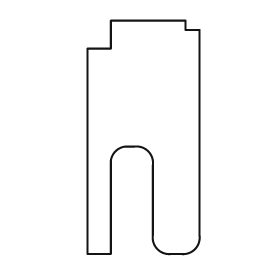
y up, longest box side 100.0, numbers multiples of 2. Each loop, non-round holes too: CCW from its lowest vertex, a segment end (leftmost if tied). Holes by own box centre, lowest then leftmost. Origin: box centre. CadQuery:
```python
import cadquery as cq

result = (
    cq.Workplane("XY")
    .moveTo(-24.0, -50.0)
    .lineTo(-14.0, -50.0)
    .lineTo(-14.0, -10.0)
    .threePointArc((-12.0, -6.0), (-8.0, -4.0))
    .lineTo(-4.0, -4.0)
    .threePointArc((2.0, -6.0), (4.0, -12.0))
    .lineTo(4.0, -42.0)
    .threePointArc((6.0, -48.0), (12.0, -50.0))
    .lineTo(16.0, -50.0)
    .threePointArc((22.0, -48.0), (24.0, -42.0))
    .lineTo(24.0, 46.0)
    .lineTo(18.0, 46.0)
    .lineTo(18.0, 50.0)
    .lineTo(-14.0, 50.0)
    .lineTo(-14.0, 38.0)
    .lineTo(-24.0, 38.0)
    .close()
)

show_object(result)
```